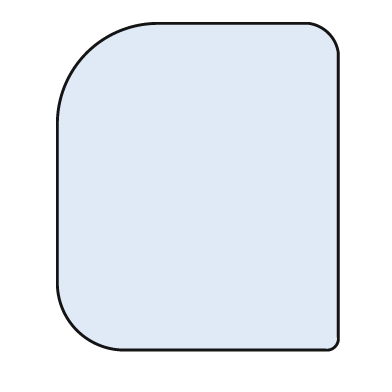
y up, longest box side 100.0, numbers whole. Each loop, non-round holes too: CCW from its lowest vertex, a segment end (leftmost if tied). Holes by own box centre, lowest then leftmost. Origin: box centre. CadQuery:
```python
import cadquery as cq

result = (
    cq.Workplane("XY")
    .moveTo(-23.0, -50.0)
    .lineTo(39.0, -50.0)
    .threePointArc((42.0, -49.0), (43.0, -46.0))
    .lineTo(43.0, 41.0)
    .threePointArc((40.0, 47.0), (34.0, 50.0))
    .lineTo(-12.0, 50.0)
    .threePointArc((-34.0, 41.0), (-43.0, 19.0))
    .lineTo(-43.0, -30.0)
    .threePointArc((-37.0, -44.0), (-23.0, -50.0))
    .close()
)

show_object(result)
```